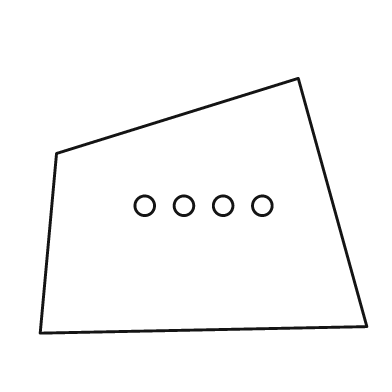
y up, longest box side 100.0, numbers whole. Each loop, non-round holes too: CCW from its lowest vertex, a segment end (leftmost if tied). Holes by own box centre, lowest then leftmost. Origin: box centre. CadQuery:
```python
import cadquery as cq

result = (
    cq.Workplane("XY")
    .moveTo(-50.0, -39.0)
    .lineTo(50.0, -37.0)
    .lineTo(29.0, 39.0)
    .lineTo(-45.0, 16.0)
    .close()
    .moveTo(-18.0, 0.0)
    .circle(3.0)
    .moveTo(-6.0, 0.0)
    .circle(3.0)
    .moveTo(6.0, 0.0)
    .circle(3.0)
    .moveTo(18.0, 0.0)
    .circle(3.0)
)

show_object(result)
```